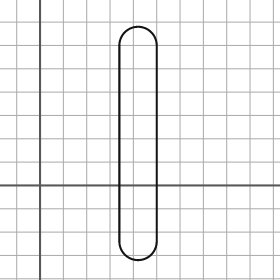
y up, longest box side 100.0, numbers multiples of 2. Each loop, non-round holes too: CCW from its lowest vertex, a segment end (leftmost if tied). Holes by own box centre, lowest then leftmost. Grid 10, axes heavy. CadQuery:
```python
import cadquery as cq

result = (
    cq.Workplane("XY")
    .moveTo(34.0, -24.0)
    .threePointArc((42.0, -32.0), (50.0, -24.0))
    .lineTo(50.0, 60.0)
    .threePointArc((42.0, 68.0), (34.0, 60.0))
    .close()
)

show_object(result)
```